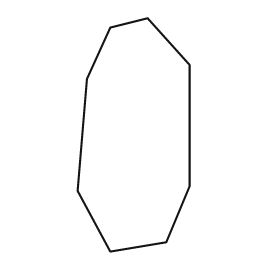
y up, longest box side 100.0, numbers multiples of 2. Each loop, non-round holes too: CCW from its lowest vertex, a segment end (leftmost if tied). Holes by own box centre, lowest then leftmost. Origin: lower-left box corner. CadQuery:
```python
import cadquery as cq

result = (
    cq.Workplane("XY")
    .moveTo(14.0, 0.0)
    .lineTo(38.0, 4.0)
    .lineTo(48.0, 28.0)
    .lineTo(48.0, 80.0)
    .lineTo(30.0, 100.0)
    .lineTo(14.0, 96.0)
    .lineTo(4.0, 74.0)
    .lineTo(0.0, 26.0)
    .close()
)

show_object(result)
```